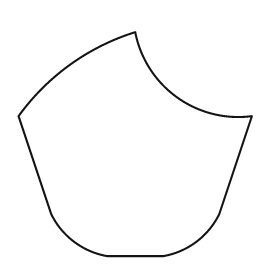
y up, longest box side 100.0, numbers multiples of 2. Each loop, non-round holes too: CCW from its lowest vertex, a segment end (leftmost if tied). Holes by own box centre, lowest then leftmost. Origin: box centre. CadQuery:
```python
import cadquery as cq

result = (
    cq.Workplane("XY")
    .moveTo(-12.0, -48.0)
    .lineTo(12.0, -48.0)
    .threePointArc((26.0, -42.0), (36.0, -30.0))
    .lineTo(50.0, 12.0)
    .threePointArc((18.0, 20.0), (0.0, 48.0))
    .threePointArc((-28.0, 34.0), (-50.0, 12.0))
    .lineTo(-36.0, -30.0)
    .threePointArc((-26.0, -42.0), (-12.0, -48.0))
    .close()
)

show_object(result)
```